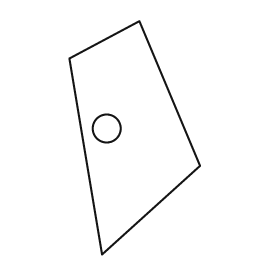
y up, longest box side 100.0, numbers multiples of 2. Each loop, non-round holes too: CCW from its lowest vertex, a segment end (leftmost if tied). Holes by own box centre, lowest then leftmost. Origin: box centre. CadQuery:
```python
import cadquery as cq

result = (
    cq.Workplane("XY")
    .moveTo(-14.0, -50.0)
    .lineTo(28.0, -12.0)
    .lineTo(2.0, 50.0)
    .lineTo(-28.0, 34.0)
    .close()
    .moveTo(-12.0, 4.0)
    .circle(6.0)
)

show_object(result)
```